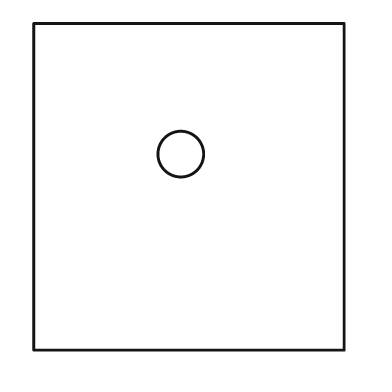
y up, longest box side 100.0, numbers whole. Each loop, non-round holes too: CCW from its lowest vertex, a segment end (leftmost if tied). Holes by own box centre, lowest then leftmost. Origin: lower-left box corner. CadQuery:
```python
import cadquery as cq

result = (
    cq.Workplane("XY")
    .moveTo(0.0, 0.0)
    .lineTo(95.0, 0.0)
    .lineTo(95.0, 100.0)
    .lineTo(0.0, 100.0)
    .close()
    .moveTo(45.0, 60.0)
    .circle(7.0)
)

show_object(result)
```